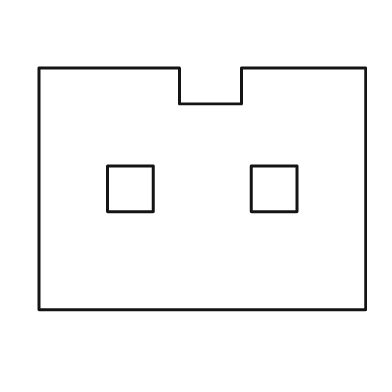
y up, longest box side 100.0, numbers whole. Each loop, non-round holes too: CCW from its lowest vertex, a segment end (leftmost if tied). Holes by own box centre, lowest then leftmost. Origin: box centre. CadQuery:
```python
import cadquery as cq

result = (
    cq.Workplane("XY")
    .moveTo(-50.0, -37.0)
    .lineTo(50.0, -37.0)
    .lineTo(50.0, 37.0)
    .lineTo(12.0, 37.0)
    .lineTo(12.0, 26.0)
    .lineTo(-7.0, 26.0)
    .lineTo(-7.0, 37.0)
    .lineTo(-50.0, 37.0)
    .close()
    .moveTo(-29.0, -7.0)
    .lineTo(-15.0, -7.0)
    .lineTo(-15.0, 7.0)
    .lineTo(-29.0, 7.0)
    .close()
    .moveTo(15.0, -7.0)
    .lineTo(29.0, -7.0)
    .lineTo(29.0, 7.0)
    .lineTo(15.0, 7.0)
    .close()
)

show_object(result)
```